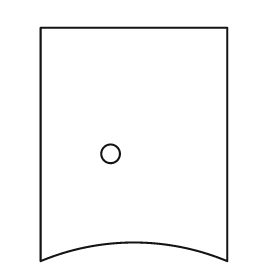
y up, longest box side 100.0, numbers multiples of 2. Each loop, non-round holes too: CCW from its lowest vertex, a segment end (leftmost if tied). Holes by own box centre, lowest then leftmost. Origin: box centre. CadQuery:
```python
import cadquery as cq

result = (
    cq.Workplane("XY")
    .moveTo(-40.0, -50.0)
    .threePointArc((0.0, -42.0), (40.0, -50.0))
    .lineTo(40.0, 50.0)
    .lineTo(-40.0, 50.0)
    .close()
    .moveTo(-10.0, -4.0)
    .circle(4.0)
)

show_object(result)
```